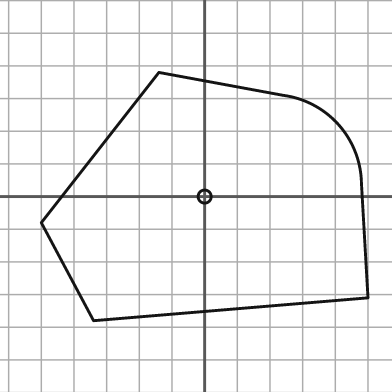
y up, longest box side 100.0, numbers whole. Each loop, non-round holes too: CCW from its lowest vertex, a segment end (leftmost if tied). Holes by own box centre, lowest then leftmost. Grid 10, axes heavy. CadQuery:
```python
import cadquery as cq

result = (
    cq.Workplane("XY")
    .moveTo(-34.0, -38.0)
    .lineTo(50.0, -31.0)
    .lineTo(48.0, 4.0)
    .threePointArc((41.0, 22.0), (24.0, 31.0))
    .lineTo(-14.0, 38.0)
    .lineTo(-50.0, -8.0)
    .close()
    .moveTo(0.0, 0.0)
    .circle(2.0)
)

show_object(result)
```